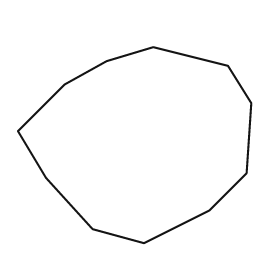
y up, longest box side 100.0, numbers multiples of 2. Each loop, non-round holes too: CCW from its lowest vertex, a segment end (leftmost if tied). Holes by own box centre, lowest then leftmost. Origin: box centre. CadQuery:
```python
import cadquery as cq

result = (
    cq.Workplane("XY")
    .moveTo(4.0, -42.0)
    .lineTo(32.0, -28.0)
    .lineTo(48.0, -12.0)
    .lineTo(50.0, 18.0)
    .lineTo(40.0, 34.0)
    .lineTo(8.0, 42.0)
    .lineTo(-12.0, 36.0)
    .lineTo(-30.0, 26.0)
    .lineTo(-50.0, 6.0)
    .lineTo(-38.0, -14.0)
    .lineTo(-18.0, -36.0)
    .close()
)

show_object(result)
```